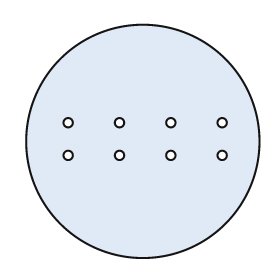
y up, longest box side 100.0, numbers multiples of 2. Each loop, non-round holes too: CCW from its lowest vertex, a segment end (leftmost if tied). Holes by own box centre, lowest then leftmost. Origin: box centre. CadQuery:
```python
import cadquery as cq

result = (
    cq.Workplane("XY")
    .moveTo(0.0, 0.0)
    .circle(50.0)
    .moveTo(-32.0, -6.0)
    .circle(2.0)
    .moveTo(-10.0, -6.0)
    .circle(2.0)
    .moveTo(12.0, -6.0)
    .circle(2.0)
    .moveTo(34.0, -6.0)
    .circle(2.0)
    .moveTo(-32.0, 8.0)
    .circle(2.0)
    .moveTo(-10.0, 8.0)
    .circle(2.0)
    .moveTo(12.0, 8.0)
    .circle(2.0)
    .moveTo(34.0, 8.0)
    .circle(2.0)
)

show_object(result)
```